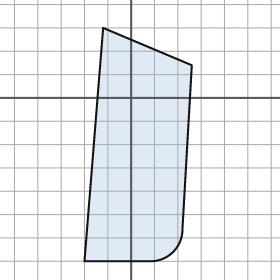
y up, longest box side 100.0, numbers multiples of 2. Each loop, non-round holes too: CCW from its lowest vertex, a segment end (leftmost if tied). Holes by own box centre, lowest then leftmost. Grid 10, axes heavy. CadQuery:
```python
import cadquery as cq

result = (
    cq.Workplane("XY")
    .moveTo(-20.0, -70.0)
    .lineTo(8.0, -70.0)
    .threePointArc((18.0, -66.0), (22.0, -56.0))
    .lineTo(26.0, 14.0)
    .lineTo(-12.0, 30.0)
    .close()
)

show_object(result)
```